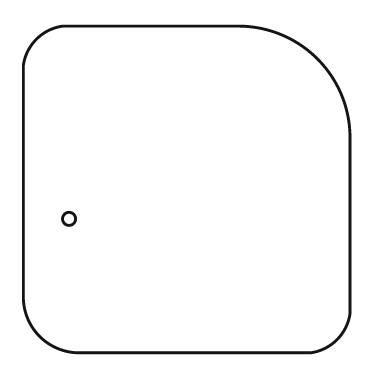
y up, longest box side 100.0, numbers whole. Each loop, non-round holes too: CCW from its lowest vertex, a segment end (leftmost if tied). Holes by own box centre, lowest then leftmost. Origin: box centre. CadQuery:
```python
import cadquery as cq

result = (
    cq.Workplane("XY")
    .moveTo(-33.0, -50.0)
    .lineTo(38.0, -50.0)
    .threePointArc((46.0, -46.0), (50.0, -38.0))
    .lineTo(50.0, 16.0)
    .threePointArc((40.0, 40.0), (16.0, 50.0))
    .lineTo(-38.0, 50.0)
    .threePointArc((-46.0, 46.0), (-50.0, 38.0))
    .lineTo(-50.0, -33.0)
    .threePointArc((-45.0, -45.0), (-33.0, -50.0))
    .close()
    .moveTo(-36.0, -9.0)
    .circle(2.0)
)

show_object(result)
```